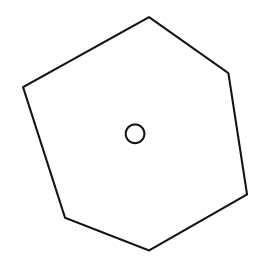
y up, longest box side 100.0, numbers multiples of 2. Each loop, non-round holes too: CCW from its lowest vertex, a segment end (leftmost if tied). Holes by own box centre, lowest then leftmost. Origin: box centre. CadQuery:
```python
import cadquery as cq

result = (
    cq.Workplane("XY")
    .moveTo(6.0, -50.0)
    .lineTo(48.0, -26.0)
    .lineTo(40.0, 26.0)
    .lineTo(6.0, 50.0)
    .lineTo(-48.0, 20.0)
    .lineTo(-30.0, -36.0)
    .close()
    .moveTo(0.0, 0.0)
    .circle(4.0)
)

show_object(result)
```